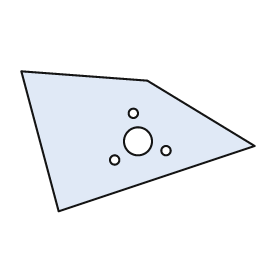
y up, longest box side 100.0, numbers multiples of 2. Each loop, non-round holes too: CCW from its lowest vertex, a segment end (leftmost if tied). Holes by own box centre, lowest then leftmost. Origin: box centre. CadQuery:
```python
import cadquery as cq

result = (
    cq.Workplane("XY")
    .moveTo(-34.0, -30.0)
    .lineTo(50.0, -2.0)
    .lineTo(4.0, 26.0)
    .lineTo(-50.0, 30.0)
    .close()
    .moveTo(-10.0, -8.0)
    .circle(2.0)
    .moveTo(12.0, -4.0)
    .circle(2.0)
    .moveTo(0.0, 0.0)
    .circle(6.0)
    .moveTo(-2.0, 12.0)
    .circle(2.0)
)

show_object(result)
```